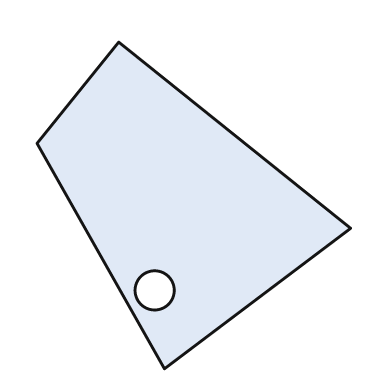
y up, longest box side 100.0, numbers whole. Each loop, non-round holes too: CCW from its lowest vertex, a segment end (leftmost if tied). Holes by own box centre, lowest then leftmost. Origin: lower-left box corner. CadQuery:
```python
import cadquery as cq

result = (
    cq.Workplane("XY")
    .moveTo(39.0, 0.0)
    .lineTo(96.0, 43.0)
    .lineTo(25.0, 100.0)
    .lineTo(0.0, 69.0)
    .close()
    .moveTo(36.0, 24.0)
    .circle(6.0)
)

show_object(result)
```